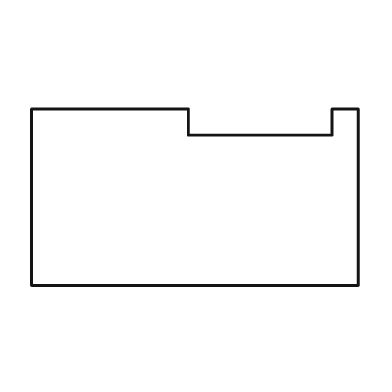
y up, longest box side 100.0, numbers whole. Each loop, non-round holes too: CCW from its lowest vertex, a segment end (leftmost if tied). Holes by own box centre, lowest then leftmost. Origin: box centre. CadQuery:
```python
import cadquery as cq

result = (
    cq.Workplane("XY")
    .moveTo(-50.0, -27.0)
    .lineTo(50.0, -27.0)
    .lineTo(50.0, 27.0)
    .lineTo(42.0, 27.0)
    .lineTo(42.0, 19.0)
    .lineTo(-2.0, 19.0)
    .lineTo(-2.0, 27.0)
    .lineTo(-50.0, 27.0)
    .close()
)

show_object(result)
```